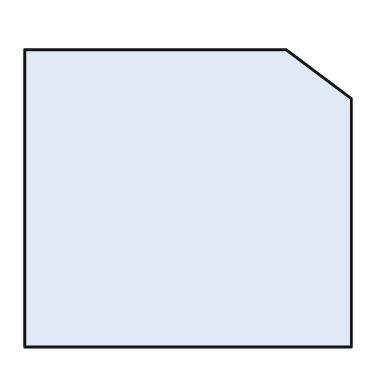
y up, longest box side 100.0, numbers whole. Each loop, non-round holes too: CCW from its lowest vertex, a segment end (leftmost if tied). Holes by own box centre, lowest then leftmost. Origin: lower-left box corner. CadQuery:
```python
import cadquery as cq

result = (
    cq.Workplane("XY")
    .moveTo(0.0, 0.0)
    .lineTo(100.0, 0.0)
    .lineTo(100.0, 76.0)
    .lineTo(80.0, 91.0)
    .lineTo(0.0, 91.0)
    .close()
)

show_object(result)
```